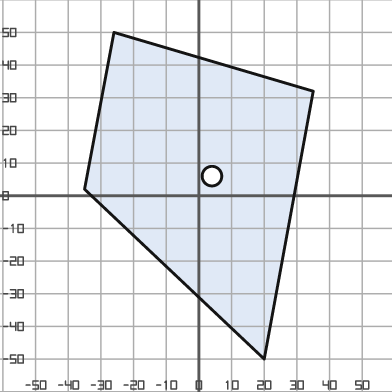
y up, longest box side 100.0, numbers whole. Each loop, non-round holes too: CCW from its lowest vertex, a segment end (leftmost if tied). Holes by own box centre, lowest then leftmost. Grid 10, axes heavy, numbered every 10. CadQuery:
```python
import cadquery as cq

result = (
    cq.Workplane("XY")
    .moveTo(20.0, -50.0)
    .lineTo(35.0, 32.0)
    .lineTo(-26.0, 50.0)
    .lineTo(-35.0, 2.0)
    .close()
    .moveTo(4.0, 6.0)
    .circle(3.0)
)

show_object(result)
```